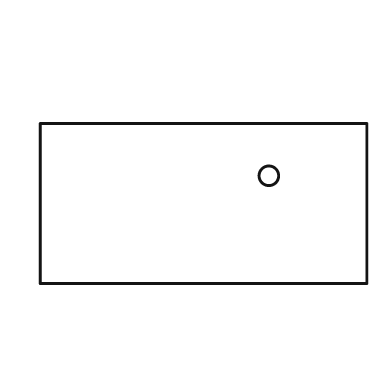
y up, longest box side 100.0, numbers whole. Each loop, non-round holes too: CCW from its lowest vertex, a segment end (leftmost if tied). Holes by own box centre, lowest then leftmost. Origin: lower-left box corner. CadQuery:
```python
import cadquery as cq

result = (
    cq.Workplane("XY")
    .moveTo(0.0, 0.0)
    .lineTo(100.0, 0.0)
    .lineTo(100.0, 49.0)
    .lineTo(0.0, 49.0)
    .close()
    .moveTo(70.0, 33.0)
    .circle(3.0)
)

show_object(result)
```